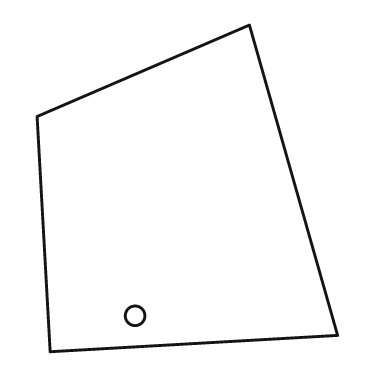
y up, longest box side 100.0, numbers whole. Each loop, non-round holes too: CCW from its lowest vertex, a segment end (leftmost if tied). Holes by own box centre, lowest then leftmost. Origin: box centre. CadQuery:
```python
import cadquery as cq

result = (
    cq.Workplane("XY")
    .moveTo(-42.0, -50.0)
    .lineTo(46.0, -45.0)
    .lineTo(19.0, 50.0)
    .lineTo(-46.0, 22.0)
    .close()
    .moveTo(-16.0, -39.0)
    .circle(3.0)
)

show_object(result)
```